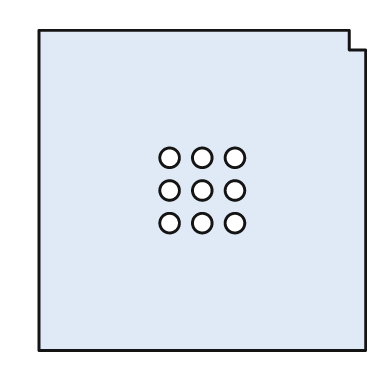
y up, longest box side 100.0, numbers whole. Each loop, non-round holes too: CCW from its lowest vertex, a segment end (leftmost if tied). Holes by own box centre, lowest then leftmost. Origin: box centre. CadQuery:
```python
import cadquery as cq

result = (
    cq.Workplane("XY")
    .moveTo(-50.0, -49.0)
    .lineTo(50.0, -49.0)
    .lineTo(50.0, 43.0)
    .lineTo(45.0, 43.0)
    .lineTo(45.0, 49.0)
    .lineTo(-50.0, 49.0)
    .close()
    .moveTo(-10.0, -10.0)
    .circle(3.0)
    .moveTo(0.0, -10.0)
    .circle(3.0)
    .moveTo(10.0, -10.0)
    .circle(3.0)
    .moveTo(-10.0, 0.0)
    .circle(3.0)
    .moveTo(0.0, 0.0)
    .circle(3.0)
    .moveTo(10.0, 0.0)
    .circle(3.0)
    .moveTo(-10.0, 10.0)
    .circle(3.0)
    .moveTo(0.0, 10.0)
    .circle(3.0)
    .moveTo(10.0, 10.0)
    .circle(3.0)
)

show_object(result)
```